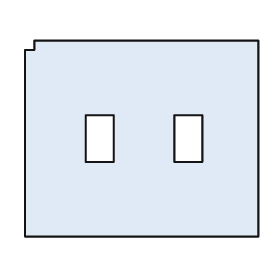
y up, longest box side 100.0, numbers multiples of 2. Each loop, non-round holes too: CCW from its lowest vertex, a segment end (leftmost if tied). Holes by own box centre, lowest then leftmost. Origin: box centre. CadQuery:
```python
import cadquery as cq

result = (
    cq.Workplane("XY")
    .moveTo(-50.0, -42.0)
    .lineTo(50.0, -42.0)
    .lineTo(50.0, 42.0)
    .lineTo(-46.0, 42.0)
    .lineTo(-46.0, 38.0)
    .lineTo(-50.0, 38.0)
    .close()
    .moveTo(-24.0, -10.0)
    .lineTo(-12.0, -10.0)
    .lineTo(-12.0, 10.0)
    .lineTo(-24.0, 10.0)
    .close()
    .moveTo(14.0, -10.0)
    .lineTo(26.0, -10.0)
    .lineTo(26.0, 10.0)
    .lineTo(14.0, 10.0)
    .close()
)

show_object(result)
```